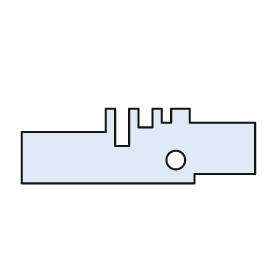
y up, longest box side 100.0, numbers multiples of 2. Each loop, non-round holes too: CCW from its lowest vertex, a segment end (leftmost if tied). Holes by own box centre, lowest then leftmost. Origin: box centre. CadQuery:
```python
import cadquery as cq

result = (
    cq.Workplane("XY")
    .moveTo(-50.0, -16.0)
    .lineTo(24.0, -16.0)
    .lineTo(24.0, -12.0)
    .lineTo(50.0, -12.0)
    .lineTo(50.0, 10.0)
    .lineTo(22.0, 10.0)
    .lineTo(22.0, 16.0)
    .lineTo(14.0, 16.0)
    .lineTo(14.0, 10.0)
    .lineTo(10.0, 10.0)
    .lineTo(10.0, 16.0)
    .lineTo(6.0, 16.0)
    .lineTo(6.0, 8.0)
    .lineTo(0.0, 8.0)
    .lineTo(0.0, 16.0)
    .lineTo(-4.0, 16.0)
    .lineTo(-4.0, 0.0)
    .lineTo(-10.0, 0.0)
    .lineTo(-10.0, 16.0)
    .lineTo(-14.0, 16.0)
    .lineTo(-14.0, 6.0)
    .lineTo(-50.0, 6.0)
    .close()
    .moveTo(16.0, -6.0)
    .circle(4.0)
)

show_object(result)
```